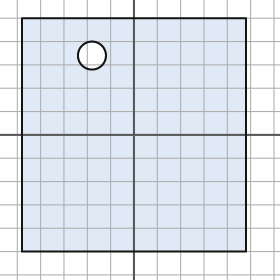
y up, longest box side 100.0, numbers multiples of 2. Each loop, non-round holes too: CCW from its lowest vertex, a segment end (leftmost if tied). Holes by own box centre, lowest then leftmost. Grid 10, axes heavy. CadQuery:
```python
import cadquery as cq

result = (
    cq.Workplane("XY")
    .moveTo(-48.0, -50.0)
    .lineTo(48.0, -50.0)
    .lineTo(48.0, 50.0)
    .lineTo(-48.0, 50.0)
    .close()
    .moveTo(-18.0, 34.0)
    .circle(6.0)
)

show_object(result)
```